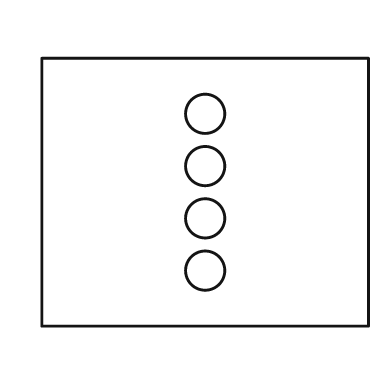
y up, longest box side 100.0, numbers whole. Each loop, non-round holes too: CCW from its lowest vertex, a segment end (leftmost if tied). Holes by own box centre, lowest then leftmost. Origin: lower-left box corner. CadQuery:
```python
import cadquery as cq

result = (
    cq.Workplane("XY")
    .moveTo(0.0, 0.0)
    .lineTo(100.0, 0.0)
    .lineTo(100.0, 82.0)
    .lineTo(0.0, 82.0)
    .close()
    .moveTo(50.0, 17.0)
    .circle(6.0)
    .moveTo(50.0, 33.0)
    .circle(6.0)
    .moveTo(50.0, 49.0)
    .circle(6.0)
    .moveTo(50.0, 65.0)
    .circle(6.0)
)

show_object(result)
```